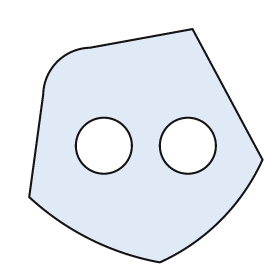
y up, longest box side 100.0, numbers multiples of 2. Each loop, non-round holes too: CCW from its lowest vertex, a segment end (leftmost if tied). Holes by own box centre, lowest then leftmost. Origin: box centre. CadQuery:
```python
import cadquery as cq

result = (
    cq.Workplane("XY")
    .moveTo(6.0, -50.0)
    .threePointArc((32.0, -32.0), (50.0, -6.0))
    .lineTo(20.0, 50.0)
    .lineTo(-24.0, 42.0)
    .threePointArc((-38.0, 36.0), (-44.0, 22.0))
    .lineTo(-50.0, -22.0)
    .threePointArc((-24.0, -40.0), (6.0, -50.0))
    .close()
    .moveTo(-18.0, 0.0)
    .circle(12.0)
    .moveTo(18.0, 0.0)
    .circle(12.0)
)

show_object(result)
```